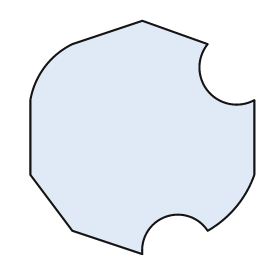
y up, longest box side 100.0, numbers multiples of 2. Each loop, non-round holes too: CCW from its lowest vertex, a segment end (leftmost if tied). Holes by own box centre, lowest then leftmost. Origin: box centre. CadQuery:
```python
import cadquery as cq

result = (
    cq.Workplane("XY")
    .moveTo(0.0, -50.0)
    .threePointArc((10.0, -34.0), (28.0, -40.0))
    .threePointArc((40.0, -30.0), (48.0, -16.0))
    .lineTo(48.0, 16.0)
    .threePointArc((28.0, 20.0), (28.0, 40.0))
    .lineTo(0.0, 50.0)
    .lineTo(-30.0, 40.0)
    .threePointArc((-42.0, 30.0), (-48.0, 16.0))
    .lineTo(-48.0, -16.0)
    .lineTo(-30.0, -40.0)
    .close()
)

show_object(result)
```